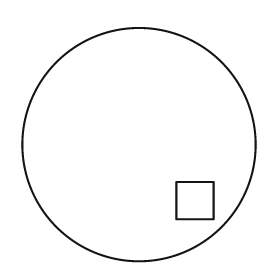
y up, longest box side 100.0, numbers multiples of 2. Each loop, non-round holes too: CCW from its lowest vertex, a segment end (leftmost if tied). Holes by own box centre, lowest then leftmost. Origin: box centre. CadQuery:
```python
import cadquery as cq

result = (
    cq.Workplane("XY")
    .moveTo(0.0, 0.0)
    .circle(50.0)
    .moveTo(16.0, -32.0)
    .lineTo(32.0, -32.0)
    .lineTo(32.0, -16.0)
    .lineTo(16.0, -16.0)
    .close()
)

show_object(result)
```